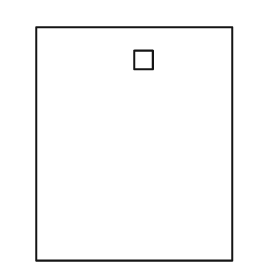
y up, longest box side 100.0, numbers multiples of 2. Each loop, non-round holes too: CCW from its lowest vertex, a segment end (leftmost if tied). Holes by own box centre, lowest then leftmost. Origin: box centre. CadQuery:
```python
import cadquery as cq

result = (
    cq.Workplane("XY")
    .moveTo(-42.0, -50.0)
    .lineTo(42.0, -50.0)
    .lineTo(42.0, 50.0)
    .lineTo(-42.0, 50.0)
    .close()
    .moveTo(0.0, 32.0)
    .lineTo(8.0, 32.0)
    .lineTo(8.0, 40.0)
    .lineTo(0.0, 40.0)
    .close()
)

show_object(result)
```